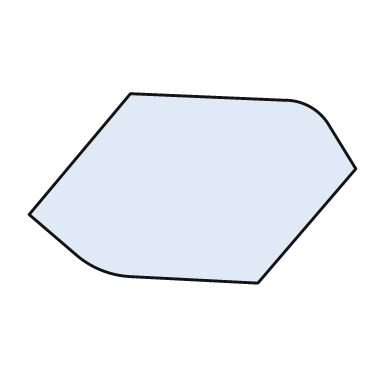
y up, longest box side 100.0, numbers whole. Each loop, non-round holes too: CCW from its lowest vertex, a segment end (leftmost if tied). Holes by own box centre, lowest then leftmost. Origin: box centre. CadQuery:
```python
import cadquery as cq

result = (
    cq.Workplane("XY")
    .moveTo(20.0, -29.0)
    .lineTo(50.0, 6.0)
    .lineTo(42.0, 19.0)
    .threePointArc((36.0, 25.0), (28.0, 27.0))
    .lineTo(-19.0, 29.0)
    .lineTo(-50.0, -8.0)
    .lineTo(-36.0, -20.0)
    .threePointArc((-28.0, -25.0), (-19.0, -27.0))
    .close()
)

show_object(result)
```